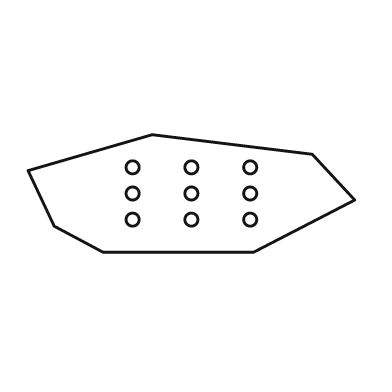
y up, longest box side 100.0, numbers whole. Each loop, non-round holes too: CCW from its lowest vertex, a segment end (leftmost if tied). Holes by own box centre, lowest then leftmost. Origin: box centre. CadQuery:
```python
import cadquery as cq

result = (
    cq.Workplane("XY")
    .moveTo(-27.0, -18.0)
    .lineTo(19.0, -18.0)
    .lineTo(50.0, -2.0)
    .lineTo(37.0, 12.0)
    .lineTo(-12.0, 18.0)
    .lineTo(-50.0, 7.0)
    .lineTo(-42.0, -10.0)
    .close()
    .moveTo(-18.0, -8.0)
    .circle(2.0)
    .moveTo(0.0, -8.0)
    .circle(2.0)
    .moveTo(18.0, -8.0)
    .circle(2.0)
    .moveTo(-18.0, 0.0)
    .circle(2.0)
    .moveTo(0.0, 0.0)
    .circle(2.0)
    .moveTo(18.0, 0.0)
    .circle(2.0)
    .moveTo(-18.0, 8.0)
    .circle(2.0)
    .moveTo(0.0, 8.0)
    .circle(2.0)
    .moveTo(18.0, 8.0)
    .circle(2.0)
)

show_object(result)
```